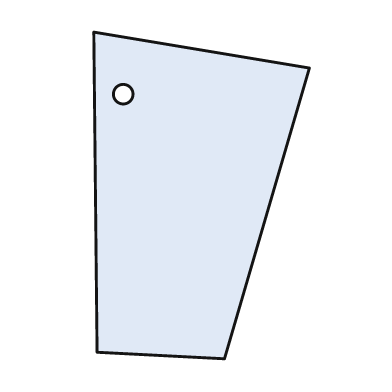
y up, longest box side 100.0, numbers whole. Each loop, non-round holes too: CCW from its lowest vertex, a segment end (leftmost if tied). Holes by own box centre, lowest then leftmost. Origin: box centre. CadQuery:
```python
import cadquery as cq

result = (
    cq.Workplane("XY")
    .moveTo(7.0, -50.0)
    .lineTo(33.0, 39.0)
    .lineTo(-33.0, 50.0)
    .lineTo(-32.0, -48.0)
    .close()
    .moveTo(-24.0, 31.0)
    .circle(3.0)
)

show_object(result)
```